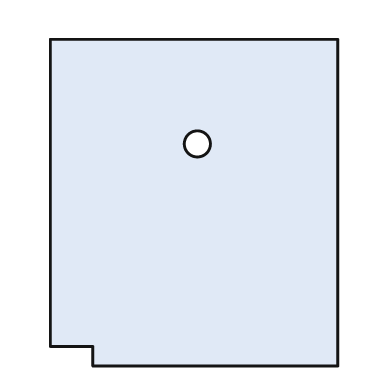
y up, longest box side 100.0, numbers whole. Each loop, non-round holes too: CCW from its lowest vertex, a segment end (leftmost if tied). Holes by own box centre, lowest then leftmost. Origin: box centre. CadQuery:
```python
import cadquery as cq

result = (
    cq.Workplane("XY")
    .moveTo(-31.0, -50.0)
    .lineTo(44.0, -50.0)
    .lineTo(44.0, 50.0)
    .lineTo(-44.0, 50.0)
    .lineTo(-44.0, -44.0)
    .lineTo(-31.0, -44.0)
    .close()
    .moveTo(1.0, 18.0)
    .circle(4.0)
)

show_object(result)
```